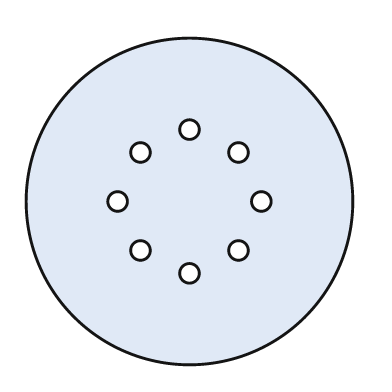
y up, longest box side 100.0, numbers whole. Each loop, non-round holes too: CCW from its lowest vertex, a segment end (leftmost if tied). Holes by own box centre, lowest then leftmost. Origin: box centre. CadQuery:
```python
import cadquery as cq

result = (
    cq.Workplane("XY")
    .moveTo(0.0, 0.0)
    .circle(50.0)
    .moveTo(0.0, -22.0)
    .circle(3.0)
    .moveTo(-15.0, -15.0)
    .circle(3.0)
    .moveTo(15.0, -15.0)
    .circle(3.0)
    .moveTo(-22.0, 0.0)
    .circle(3.0)
    .moveTo(22.0, 0.0)
    .circle(3.0)
    .moveTo(-15.0, 15.0)
    .circle(3.0)
    .moveTo(15.0, 15.0)
    .circle(3.0)
    .moveTo(0.0, 22.0)
    .circle(3.0)
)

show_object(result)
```